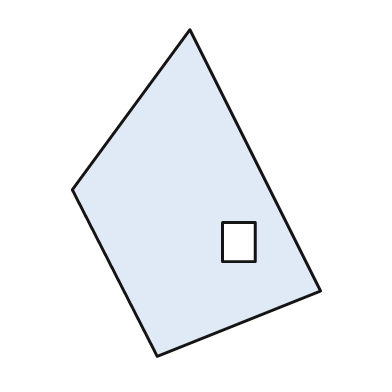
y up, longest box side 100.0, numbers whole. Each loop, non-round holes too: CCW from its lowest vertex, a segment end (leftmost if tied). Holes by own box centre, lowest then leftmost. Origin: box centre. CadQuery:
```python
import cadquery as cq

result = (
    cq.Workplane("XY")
    .moveTo(-12.0, -50.0)
    .lineTo(38.0, -30.0)
    .lineTo(-2.0, 50.0)
    .lineTo(-38.0, 1.0)
    .close()
    .moveTo(8.0, -21.0)
    .lineTo(18.0, -21.0)
    .lineTo(18.0, -9.0)
    .lineTo(8.0, -9.0)
    .close()
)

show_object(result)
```